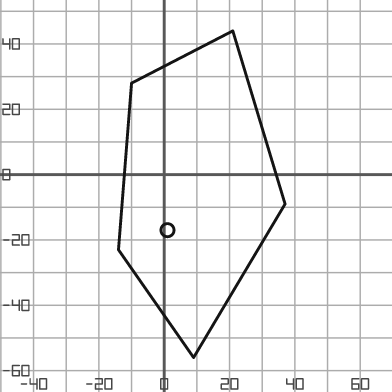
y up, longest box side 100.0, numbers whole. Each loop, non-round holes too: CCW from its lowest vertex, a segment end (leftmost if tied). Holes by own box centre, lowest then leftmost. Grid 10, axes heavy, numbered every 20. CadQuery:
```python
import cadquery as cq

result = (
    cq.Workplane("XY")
    .moveTo(9.0, -56.0)
    .lineTo(37.0, -9.0)
    .lineTo(21.0, 44.0)
    .lineTo(-10.0, 28.0)
    .lineTo(-14.0, -23.0)
    .close()
    .moveTo(1.0, -17.0)
    .circle(2.0)
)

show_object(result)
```